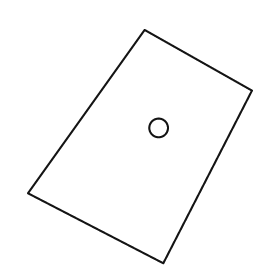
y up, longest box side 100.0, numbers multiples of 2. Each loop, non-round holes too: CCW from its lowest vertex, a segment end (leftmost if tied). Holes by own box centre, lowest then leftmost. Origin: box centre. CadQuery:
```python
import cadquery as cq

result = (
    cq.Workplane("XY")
    .moveTo(10.0, -50.0)
    .lineTo(48.0, 24.0)
    .lineTo(2.0, 50.0)
    .lineTo(-48.0, -20.0)
    .close()
    .moveTo(8.0, 8.0)
    .circle(4.0)
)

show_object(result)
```